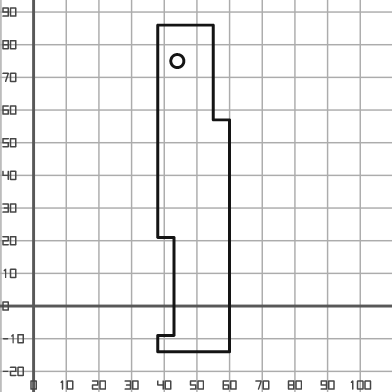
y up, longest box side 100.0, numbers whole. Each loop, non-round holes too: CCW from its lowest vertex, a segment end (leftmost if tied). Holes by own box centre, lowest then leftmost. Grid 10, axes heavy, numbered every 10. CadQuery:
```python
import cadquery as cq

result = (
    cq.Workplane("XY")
    .moveTo(38.0, -14.0)
    .lineTo(60.0, -14.0)
    .lineTo(60.0, 57.0)
    .lineTo(55.0, 57.0)
    .lineTo(55.0, 86.0)
    .lineTo(38.0, 86.0)
    .lineTo(38.0, 21.0)
    .lineTo(43.0, 21.0)
    .lineTo(43.0, -9.0)
    .lineTo(38.0, -9.0)
    .close()
    .moveTo(44.0, 75.0)
    .circle(2.0)
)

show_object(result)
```